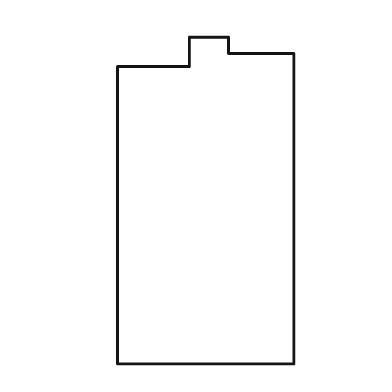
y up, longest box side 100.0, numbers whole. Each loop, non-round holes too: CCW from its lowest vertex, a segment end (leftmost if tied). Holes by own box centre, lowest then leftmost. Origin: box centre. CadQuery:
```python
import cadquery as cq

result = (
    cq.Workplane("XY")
    .moveTo(-27.0, -50.0)
    .lineTo(27.0, -50.0)
    .lineTo(27.0, 45.0)
    .lineTo(7.0, 45.0)
    .lineTo(7.0, 50.0)
    .lineTo(-5.0, 50.0)
    .lineTo(-5.0, 41.0)
    .lineTo(-27.0, 41.0)
    .close()
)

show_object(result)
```